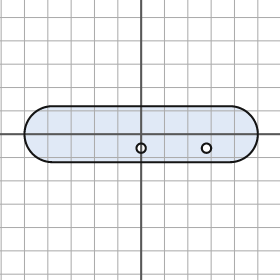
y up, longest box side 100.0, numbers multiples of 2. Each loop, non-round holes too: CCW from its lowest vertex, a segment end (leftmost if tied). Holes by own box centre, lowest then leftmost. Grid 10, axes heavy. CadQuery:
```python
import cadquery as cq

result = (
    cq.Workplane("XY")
    .moveTo(-38.0, -12.0)
    .lineTo(38.0, -12.0)
    .threePointArc((50.0, 0.0), (38.0, 12.0))
    .lineTo(-38.0, 12.0)
    .threePointArc((-50.0, 0.0), (-38.0, -12.0))
    .close()
    .moveTo(0.0, -6.0)
    .circle(2.0)
    .moveTo(28.0, -6.0)
    .circle(2.0)
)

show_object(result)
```